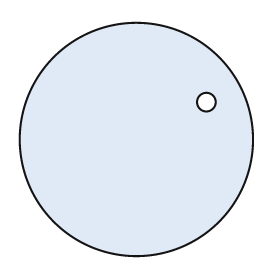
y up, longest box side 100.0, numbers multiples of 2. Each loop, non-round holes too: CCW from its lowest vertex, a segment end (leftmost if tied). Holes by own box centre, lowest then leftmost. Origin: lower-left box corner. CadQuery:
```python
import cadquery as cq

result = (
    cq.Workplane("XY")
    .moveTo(50.0, 50.0)
    .circle(50.0)
    .moveTo(80.0, 66.0)
    .circle(4.0)
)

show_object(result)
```